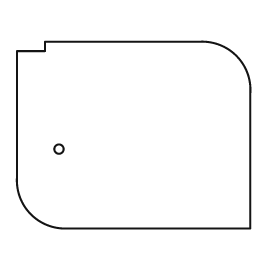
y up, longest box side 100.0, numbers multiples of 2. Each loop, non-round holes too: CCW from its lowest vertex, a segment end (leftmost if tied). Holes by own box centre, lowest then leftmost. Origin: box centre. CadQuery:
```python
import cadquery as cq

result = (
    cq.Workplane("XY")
    .moveTo(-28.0, -40.0)
    .lineTo(50.0, -40.0)
    .lineTo(50.0, 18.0)
    .threePointArc((44.0, 34.0), (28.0, 40.0))
    .lineTo(-38.0, 40.0)
    .lineTo(-38.0, 36.0)
    .lineTo(-50.0, 36.0)
    .lineTo(-50.0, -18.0)
    .threePointArc((-44.0, -34.0), (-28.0, -40.0))
    .close()
    .moveTo(-32.0, -6.0)
    .circle(2.0)
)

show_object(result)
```